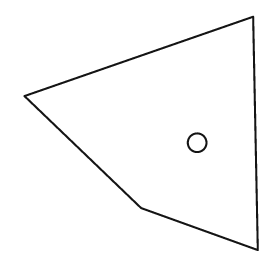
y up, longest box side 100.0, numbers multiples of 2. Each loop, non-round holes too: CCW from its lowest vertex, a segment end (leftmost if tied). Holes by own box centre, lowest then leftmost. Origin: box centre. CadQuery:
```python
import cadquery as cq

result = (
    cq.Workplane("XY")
    .moveTo(50.0, -50.0)
    .lineTo(48.0, 50.0)
    .lineTo(-50.0, 16.0)
    .lineTo(0.0, -32.0)
    .close()
    .moveTo(24.0, -4.0)
    .circle(4.0)
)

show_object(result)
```